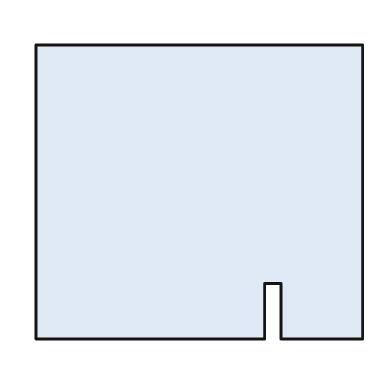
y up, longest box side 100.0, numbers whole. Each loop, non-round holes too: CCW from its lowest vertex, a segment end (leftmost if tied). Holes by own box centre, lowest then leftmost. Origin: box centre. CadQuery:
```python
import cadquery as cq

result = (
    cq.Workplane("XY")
    .moveTo(-50.0, -45.0)
    .lineTo(20.0, -45.0)
    .lineTo(20.0, -28.0)
    .lineTo(25.0, -28.0)
    .lineTo(25.0, -45.0)
    .lineTo(50.0, -45.0)
    .lineTo(50.0, 45.0)
    .lineTo(-50.0, 45.0)
    .close()
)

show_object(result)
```